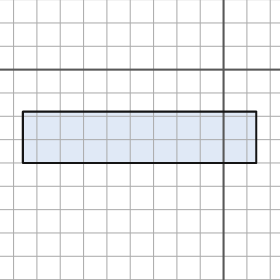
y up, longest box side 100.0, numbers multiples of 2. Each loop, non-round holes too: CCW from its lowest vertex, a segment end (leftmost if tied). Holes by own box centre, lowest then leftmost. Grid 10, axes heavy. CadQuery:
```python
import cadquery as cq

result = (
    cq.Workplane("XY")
    .moveTo(-86.0, -40.0)
    .lineTo(14.0, -40.0)
    .lineTo(14.0, -18.0)
    .lineTo(-86.0, -18.0)
    .close()
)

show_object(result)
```